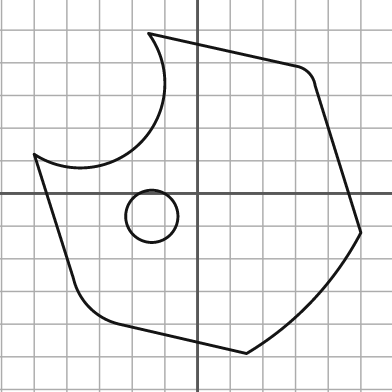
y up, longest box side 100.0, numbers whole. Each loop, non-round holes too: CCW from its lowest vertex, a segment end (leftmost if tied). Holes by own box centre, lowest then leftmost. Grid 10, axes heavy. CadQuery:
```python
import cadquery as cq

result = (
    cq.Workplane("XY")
    .moveTo(15.0, -49.0)
    .threePointArc((35.0, -33.0), (50.0, -12.0))
    .lineTo(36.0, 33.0)
    .threePointArc((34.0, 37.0), (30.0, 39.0))
    .lineTo(-15.0, 49.0)
    .threePointArc((-17.0, 16.0), (-50.0, 12.0))
    .lineTo(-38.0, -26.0)
    .threePointArc((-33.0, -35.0), (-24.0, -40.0))
    .close()
    .moveTo(-14.0, -7.0)
    .circle(8.0)
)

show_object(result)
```